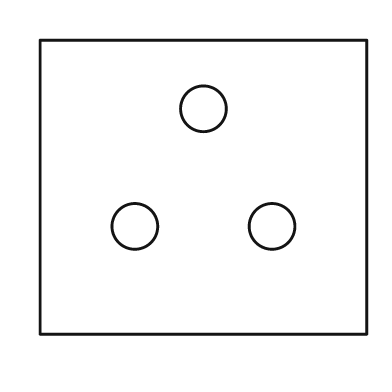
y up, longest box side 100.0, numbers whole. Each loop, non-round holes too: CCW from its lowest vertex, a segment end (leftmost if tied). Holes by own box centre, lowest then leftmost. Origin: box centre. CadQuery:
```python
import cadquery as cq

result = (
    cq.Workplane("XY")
    .moveTo(-50.0, -45.0)
    .lineTo(50.0, -45.0)
    .lineTo(50.0, 45.0)
    .lineTo(-50.0, 45.0)
    .close()
    .moveTo(-21.0, -12.0)
    .circle(7.0)
    .moveTo(21.0, -12.0)
    .circle(7.0)
    .moveTo(0.0, 24.0)
    .circle(7.0)
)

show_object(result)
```